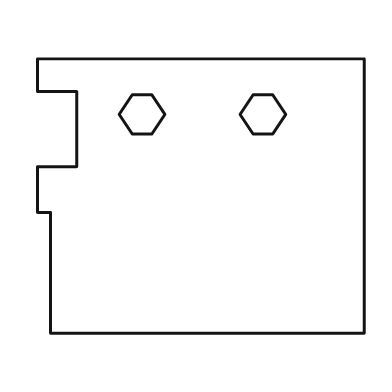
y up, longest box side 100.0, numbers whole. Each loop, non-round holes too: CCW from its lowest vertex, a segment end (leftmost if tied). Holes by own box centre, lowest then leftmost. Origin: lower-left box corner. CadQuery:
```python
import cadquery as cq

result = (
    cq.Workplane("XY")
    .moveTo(4.0, 0.0)
    .lineTo(100.0, 0.0)
    .lineTo(100.0, 84.0)
    .lineTo(0.0, 84.0)
    .lineTo(0.0, 74.0)
    .lineTo(12.0, 74.0)
    .lineTo(12.0, 51.0)
    .lineTo(0.0, 51.0)
    .lineTo(0.0, 37.0)
    .lineTo(4.0, 37.0)
    .close()
    .moveTo(29.0, 61.0)
    .lineTo(35.0, 61.0)
    .lineTo(39.0, 67.0)
    .lineTo(35.0, 73.0)
    .lineTo(29.0, 73.0)
    .lineTo(25.0, 67.0)
    .close()
    .moveTo(66.0, 61.0)
    .lineTo(72.0, 61.0)
    .lineTo(76.0, 67.0)
    .lineTo(72.0, 73.0)
    .lineTo(66.0, 73.0)
    .lineTo(62.0, 67.0)
    .close()
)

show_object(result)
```